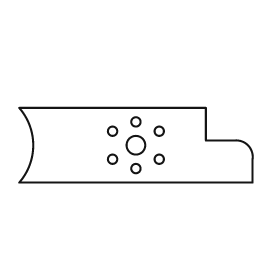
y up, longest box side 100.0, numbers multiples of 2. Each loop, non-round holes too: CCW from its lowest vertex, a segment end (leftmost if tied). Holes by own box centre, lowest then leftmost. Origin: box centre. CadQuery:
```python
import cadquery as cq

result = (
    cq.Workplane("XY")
    .moveTo(-50.0, -16.0)
    .lineTo(50.0, -16.0)
    .lineTo(50.0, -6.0)
    .threePointArc((48.0, 0.0), (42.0, 2.0))
    .lineTo(30.0, 2.0)
    .lineTo(30.0, 16.0)
    .lineTo(-50.0, 16.0)
    .threePointArc((-44.0, 0.0), (-50.0, -16.0))
    .close()
    .moveTo(0.0, -10.0)
    .circle(2.0)
    .moveTo(-10.0, -6.0)
    .circle(2.0)
    .moveTo(10.0, -6.0)
    .circle(2.0)
    .moveTo(0.0, 0.0)
    .circle(4.0)
    .moveTo(-10.0, 6.0)
    .circle(2.0)
    .moveTo(10.0, 6.0)
    .circle(2.0)
    .moveTo(0.0, 10.0)
    .circle(2.0)
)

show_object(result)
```